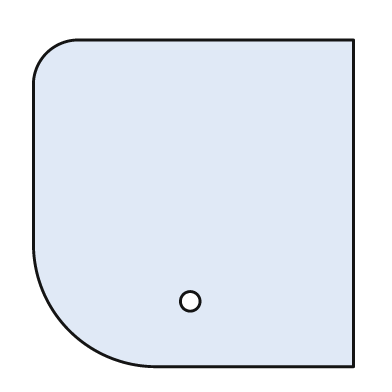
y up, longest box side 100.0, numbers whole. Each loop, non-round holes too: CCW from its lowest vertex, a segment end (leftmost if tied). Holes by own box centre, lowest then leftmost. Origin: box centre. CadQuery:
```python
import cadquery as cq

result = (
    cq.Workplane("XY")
    .moveTo(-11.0, -50.0)
    .lineTo(49.0, -50.0)
    .lineTo(49.0, 50.0)
    .lineTo(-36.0, 50.0)
    .threePointArc((-45.0, 46.0), (-49.0, 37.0))
    .lineTo(-49.0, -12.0)
    .threePointArc((-38.0, -39.0), (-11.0, -50.0))
    .close()
    .moveTo(-1.0, -30.0)
    .circle(3.0)
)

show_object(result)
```